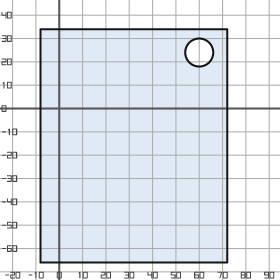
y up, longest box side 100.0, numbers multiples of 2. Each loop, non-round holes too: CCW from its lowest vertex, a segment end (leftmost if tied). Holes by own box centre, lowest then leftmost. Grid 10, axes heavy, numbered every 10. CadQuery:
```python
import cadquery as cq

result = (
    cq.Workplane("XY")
    .moveTo(-8.0, -66.0)
    .lineTo(72.0, -66.0)
    .lineTo(72.0, 34.0)
    .lineTo(-8.0, 34.0)
    .close()
    .moveTo(60.0, 24.0)
    .circle(6.0)
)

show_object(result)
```